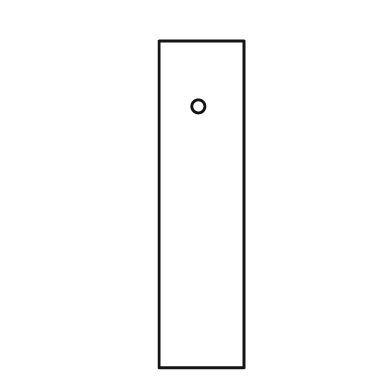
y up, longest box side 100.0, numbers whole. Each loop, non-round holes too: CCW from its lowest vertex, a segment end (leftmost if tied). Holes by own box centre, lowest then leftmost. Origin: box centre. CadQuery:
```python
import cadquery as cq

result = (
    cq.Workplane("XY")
    .moveTo(-13.0, -50.0)
    .lineTo(13.0, -50.0)
    .lineTo(13.0, 50.0)
    .lineTo(-13.0, 50.0)
    .close()
    .moveTo(-1.0, 30.0)
    .circle(2.0)
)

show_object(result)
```